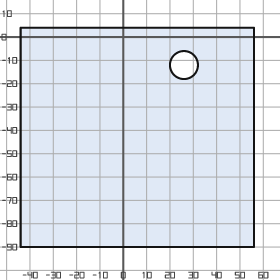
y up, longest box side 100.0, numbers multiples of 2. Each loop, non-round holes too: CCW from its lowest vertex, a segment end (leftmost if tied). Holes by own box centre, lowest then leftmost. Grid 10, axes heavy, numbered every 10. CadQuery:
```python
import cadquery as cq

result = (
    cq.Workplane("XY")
    .moveTo(-44.0, -90.0)
    .lineTo(56.0, -90.0)
    .lineTo(56.0, 4.0)
    .lineTo(-44.0, 4.0)
    .close()
    .moveTo(26.0, -12.0)
    .circle(6.0)
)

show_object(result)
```